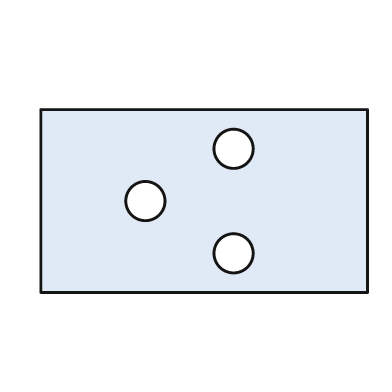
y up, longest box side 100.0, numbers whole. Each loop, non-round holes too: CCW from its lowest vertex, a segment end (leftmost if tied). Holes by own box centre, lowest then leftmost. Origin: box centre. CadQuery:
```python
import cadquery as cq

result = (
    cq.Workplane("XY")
    .moveTo(-50.0, -28.0)
    .lineTo(50.0, -28.0)
    .lineTo(50.0, 28.0)
    .lineTo(-50.0, 28.0)
    .close()
    .moveTo(9.0, -16.0)
    .circle(6.0)
    .moveTo(-18.0, 0.0)
    .circle(6.0)
    .moveTo(9.0, 16.0)
    .circle(6.0)
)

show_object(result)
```